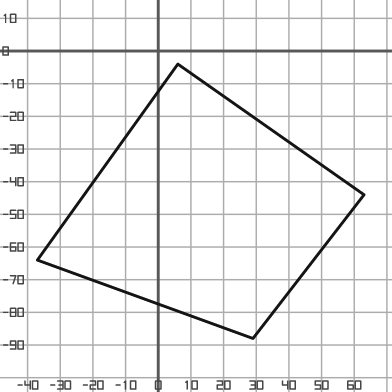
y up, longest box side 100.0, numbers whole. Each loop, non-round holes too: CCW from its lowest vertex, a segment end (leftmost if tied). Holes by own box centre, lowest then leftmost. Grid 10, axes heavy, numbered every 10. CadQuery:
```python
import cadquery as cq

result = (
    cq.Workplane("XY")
    .moveTo(29.0, -88.0)
    .lineTo(63.0, -44.0)
    .lineTo(6.0, -4.0)
    .lineTo(-37.0, -64.0)
    .close()
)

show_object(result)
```